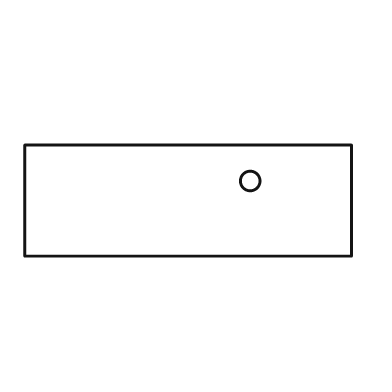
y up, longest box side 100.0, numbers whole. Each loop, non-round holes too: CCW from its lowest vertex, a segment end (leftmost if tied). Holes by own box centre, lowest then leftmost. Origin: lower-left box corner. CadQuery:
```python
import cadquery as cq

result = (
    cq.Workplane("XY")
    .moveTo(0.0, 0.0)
    .lineTo(100.0, 0.0)
    .lineTo(100.0, 34.0)
    .lineTo(0.0, 34.0)
    .close()
    .moveTo(69.0, 23.0)
    .circle(3.0)
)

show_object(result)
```